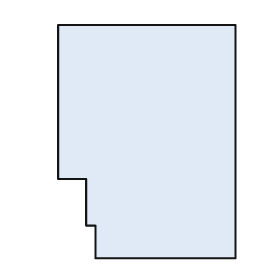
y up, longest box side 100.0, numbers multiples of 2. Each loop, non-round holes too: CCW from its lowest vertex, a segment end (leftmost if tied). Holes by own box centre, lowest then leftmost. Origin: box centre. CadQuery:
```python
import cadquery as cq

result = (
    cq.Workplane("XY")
    .moveTo(-22.0, -50.0)
    .lineTo(38.0, -50.0)
    .lineTo(38.0, 50.0)
    .lineTo(-38.0, 50.0)
    .lineTo(-38.0, -16.0)
    .lineTo(-26.0, -16.0)
    .lineTo(-26.0, -36.0)
    .lineTo(-22.0, -36.0)
    .close()
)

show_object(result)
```